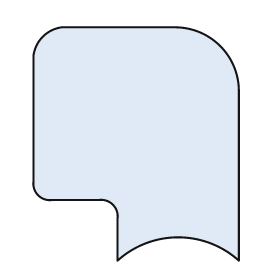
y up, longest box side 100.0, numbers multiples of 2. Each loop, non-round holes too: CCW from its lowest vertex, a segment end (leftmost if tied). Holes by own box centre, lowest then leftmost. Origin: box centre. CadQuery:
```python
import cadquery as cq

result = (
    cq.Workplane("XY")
    .moveTo(-8.0, -50.0)
    .threePointArc((18.0, -40.0), (44.0, -50.0))
    .lineTo(44.0, 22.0)
    .threePointArc((36.0, 42.0), (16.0, 50.0))
    .lineTo(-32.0, 50.0)
    .threePointArc((-40.0, 46.0), (-44.0, 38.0))
    .lineTo(-44.0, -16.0)
    .threePointArc((-42.0, -22.0), (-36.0, -24.0))
    .lineTo(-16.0, -24.0)
    .threePointArc((-10.0, -26.0), (-8.0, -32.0))
    .close()
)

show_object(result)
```